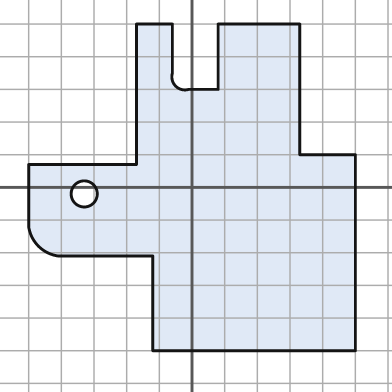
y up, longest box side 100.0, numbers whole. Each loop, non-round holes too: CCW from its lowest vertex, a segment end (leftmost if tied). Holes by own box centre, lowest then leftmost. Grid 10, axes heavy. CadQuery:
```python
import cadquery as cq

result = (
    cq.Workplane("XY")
    .moveTo(-12.0, -50.0)
    .lineTo(50.0, -50.0)
    .lineTo(50.0, 10.0)
    .lineTo(33.0, 10.0)
    .lineTo(33.0, 50.0)
    .lineTo(8.0, 50.0)
    .lineTo(8.0, 30.0)
    .lineTo(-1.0, 30.0)
    .threePointArc((-5.0, 31.0), (-6.0, 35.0))
    .lineTo(-6.0, 50.0)
    .lineTo(-17.0, 50.0)
    .lineTo(-17.0, 7.0)
    .lineTo(-50.0, 7.0)
    .lineTo(-50.0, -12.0)
    .threePointArc((-47.0, -18.0), (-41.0, -21.0))
    .lineTo(-12.0, -21.0)
    .close()
    .moveTo(-33.0, -2.0)
    .circle(4.0)
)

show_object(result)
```